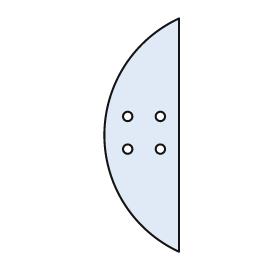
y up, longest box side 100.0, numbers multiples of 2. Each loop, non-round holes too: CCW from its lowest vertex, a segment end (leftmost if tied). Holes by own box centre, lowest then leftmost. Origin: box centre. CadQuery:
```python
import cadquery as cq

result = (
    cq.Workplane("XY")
    .moveTo(16.0, -50.0)
    .lineTo(16.0, 50.0)
    .threePointArc((-16.0, 0.0), (16.0, -50.0))
    .close()
    .moveTo(-6.0, -6.0)
    .circle(2.0)
    .moveTo(8.0, -6.0)
    .circle(2.0)
    .moveTo(-6.0, 8.0)
    .circle(2.0)
    .moveTo(8.0, 8.0)
    .circle(2.0)
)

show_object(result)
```